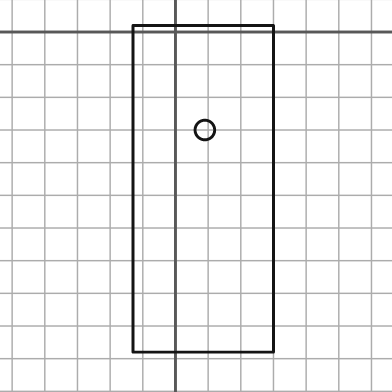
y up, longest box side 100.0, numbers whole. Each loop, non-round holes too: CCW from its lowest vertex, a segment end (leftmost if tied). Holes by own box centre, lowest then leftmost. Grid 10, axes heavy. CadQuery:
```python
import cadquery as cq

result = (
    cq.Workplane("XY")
    .moveTo(-13.0, -98.0)
    .lineTo(30.0, -98.0)
    .lineTo(30.0, 2.0)
    .lineTo(-13.0, 2.0)
    .close()
    .moveTo(9.0, -30.0)
    .circle(3.0)
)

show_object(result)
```